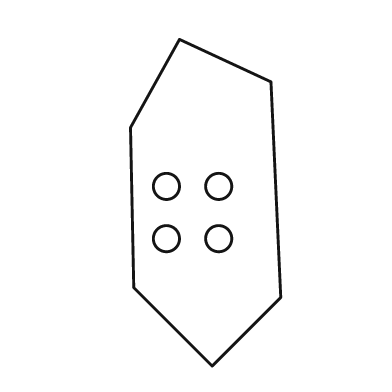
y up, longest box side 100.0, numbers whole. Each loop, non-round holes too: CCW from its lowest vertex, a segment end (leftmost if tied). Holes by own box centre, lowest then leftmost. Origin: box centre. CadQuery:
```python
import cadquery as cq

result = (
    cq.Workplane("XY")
    .moveTo(2.0, -50.0)
    .lineTo(23.0, -29.0)
    .lineTo(20.0, 37.0)
    .lineTo(-8.0, 50.0)
    .lineTo(-23.0, 23.0)
    .lineTo(-22.0, -26.0)
    .close()
    .moveTo(-12.0, -11.0)
    .circle(4.0)
    .moveTo(4.0, -11.0)
    .circle(4.0)
    .moveTo(-12.0, 5.0)
    .circle(4.0)
    .moveTo(4.0, 5.0)
    .circle(4.0)
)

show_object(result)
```